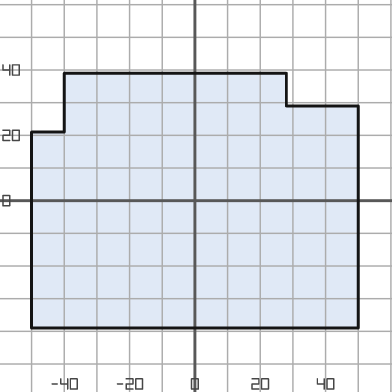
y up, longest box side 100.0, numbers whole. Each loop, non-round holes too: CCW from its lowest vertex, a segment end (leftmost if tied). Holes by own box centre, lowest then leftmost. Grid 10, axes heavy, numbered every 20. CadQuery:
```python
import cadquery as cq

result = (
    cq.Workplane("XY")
    .moveTo(-50.0, -39.0)
    .lineTo(50.0, -39.0)
    .lineTo(50.0, 29.0)
    .lineTo(28.0, 29.0)
    .lineTo(28.0, 39.0)
    .lineTo(-40.0, 39.0)
    .lineTo(-40.0, 21.0)
    .lineTo(-50.0, 21.0)
    .close()
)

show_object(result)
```